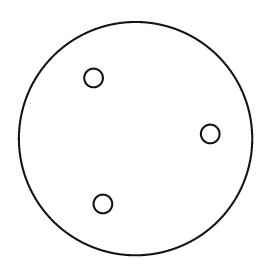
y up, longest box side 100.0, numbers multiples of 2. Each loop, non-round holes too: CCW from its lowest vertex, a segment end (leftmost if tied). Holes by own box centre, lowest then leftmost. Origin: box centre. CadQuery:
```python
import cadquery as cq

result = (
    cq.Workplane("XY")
    .moveTo(0.0, 0.0)
    .circle(50.0)
    .moveTo(-14.0, -28.0)
    .circle(4.0)
    .moveTo(32.0, 2.0)
    .circle(4.0)
    .moveTo(-18.0, 26.0)
    .circle(4.0)
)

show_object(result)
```